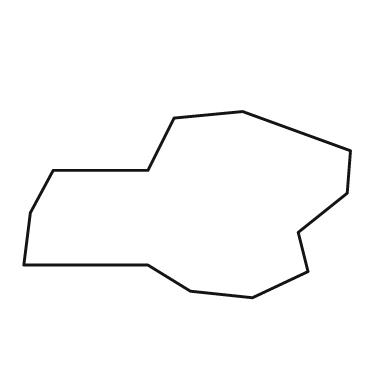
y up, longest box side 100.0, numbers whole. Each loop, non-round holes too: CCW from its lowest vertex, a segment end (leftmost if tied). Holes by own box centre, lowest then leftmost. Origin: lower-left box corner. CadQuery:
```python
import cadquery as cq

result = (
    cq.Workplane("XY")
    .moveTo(70.0, 0.0)
    .lineTo(87.0, 8.0)
    .lineTo(84.0, 20.0)
    .lineTo(99.0, 32.0)
    .lineTo(100.0, 45.0)
    .lineTo(67.0, 57.0)
    .lineTo(46.0, 55.0)
    .lineTo(38.0, 39.0)
    .lineTo(9.0, 39.0)
    .lineTo(2.0, 26.0)
    .lineTo(0.0, 10.0)
    .lineTo(38.0, 10.0)
    .lineTo(51.0, 2.0)
    .close()
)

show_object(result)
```